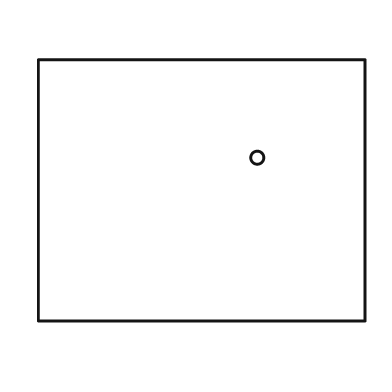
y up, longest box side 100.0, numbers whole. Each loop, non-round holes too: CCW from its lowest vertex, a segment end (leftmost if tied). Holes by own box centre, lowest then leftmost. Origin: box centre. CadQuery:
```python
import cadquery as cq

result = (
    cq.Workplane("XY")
    .moveTo(-50.0, -40.0)
    .lineTo(50.0, -40.0)
    .lineTo(50.0, 40.0)
    .lineTo(-50.0, 40.0)
    .close()
    .moveTo(17.0, 10.0)
    .circle(2.0)
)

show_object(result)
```